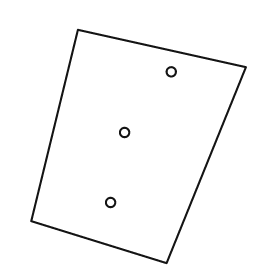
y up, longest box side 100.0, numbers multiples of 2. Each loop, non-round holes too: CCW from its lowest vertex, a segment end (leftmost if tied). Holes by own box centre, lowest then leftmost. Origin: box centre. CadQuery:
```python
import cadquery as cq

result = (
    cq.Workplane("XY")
    .moveTo(12.0, -50.0)
    .lineTo(46.0, 34.0)
    .lineTo(-26.0, 50.0)
    .lineTo(-46.0, -32.0)
    .close()
    .moveTo(-12.0, -24.0)
    .circle(2.0)
    .moveTo(-6.0, 6.0)
    .circle(2.0)
    .moveTo(14.0, 32.0)
    .circle(2.0)
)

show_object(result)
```